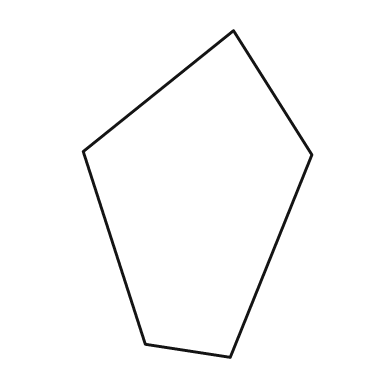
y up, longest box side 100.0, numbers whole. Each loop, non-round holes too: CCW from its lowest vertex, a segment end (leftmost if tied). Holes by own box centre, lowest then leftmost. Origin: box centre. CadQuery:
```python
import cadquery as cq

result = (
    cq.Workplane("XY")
    .moveTo(10.0, -50.0)
    .lineTo(35.0, 12.0)
    .lineTo(11.0, 50.0)
    .lineTo(-35.0, 13.0)
    .lineTo(-16.0, -46.0)
    .close()
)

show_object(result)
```